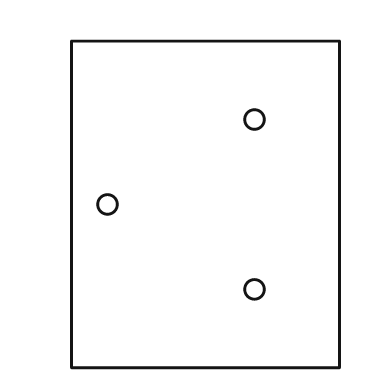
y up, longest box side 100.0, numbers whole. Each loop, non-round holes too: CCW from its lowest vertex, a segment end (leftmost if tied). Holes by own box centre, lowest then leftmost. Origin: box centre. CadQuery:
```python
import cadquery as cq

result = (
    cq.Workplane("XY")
    .moveTo(-41.0, -50.0)
    .lineTo(41.0, -50.0)
    .lineTo(41.0, 50.0)
    .lineTo(-41.0, 50.0)
    .close()
    .moveTo(15.0, -26.0)
    .circle(3.0)
    .moveTo(-30.0, 0.0)
    .circle(3.0)
    .moveTo(15.0, 26.0)
    .circle(3.0)
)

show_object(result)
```